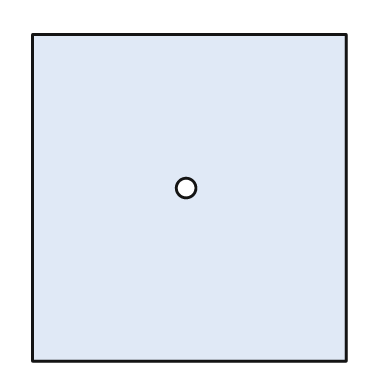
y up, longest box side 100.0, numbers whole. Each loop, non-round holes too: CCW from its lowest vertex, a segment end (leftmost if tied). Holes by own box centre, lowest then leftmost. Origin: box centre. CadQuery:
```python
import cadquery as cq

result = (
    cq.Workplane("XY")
    .moveTo(-48.0, -50.0)
    .lineTo(48.0, -50.0)
    .lineTo(48.0, 50.0)
    .lineTo(-48.0, 50.0)
    .close()
    .moveTo(-1.0, 3.0)
    .circle(3.0)
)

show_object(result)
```